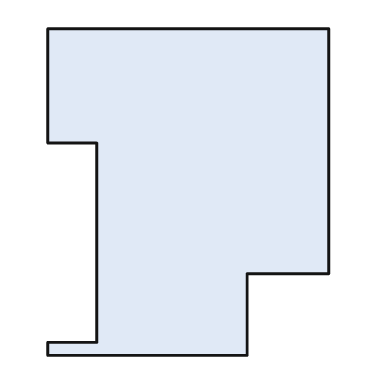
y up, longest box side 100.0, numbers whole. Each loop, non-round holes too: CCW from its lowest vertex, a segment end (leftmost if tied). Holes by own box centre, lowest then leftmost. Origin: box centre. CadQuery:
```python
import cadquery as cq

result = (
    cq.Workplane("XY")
    .moveTo(-43.0, -50.0)
    .lineTo(18.0, -50.0)
    .lineTo(18.0, -25.0)
    .lineTo(43.0, -25.0)
    .lineTo(43.0, 50.0)
    .lineTo(-43.0, 50.0)
    .lineTo(-43.0, 15.0)
    .lineTo(-28.0, 15.0)
    .lineTo(-28.0, -46.0)
    .lineTo(-43.0, -46.0)
    .close()
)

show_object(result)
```